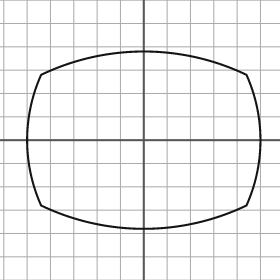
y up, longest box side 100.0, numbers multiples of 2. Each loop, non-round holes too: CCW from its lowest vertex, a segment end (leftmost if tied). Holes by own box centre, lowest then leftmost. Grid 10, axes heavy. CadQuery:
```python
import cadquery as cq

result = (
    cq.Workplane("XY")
    .moveTo(-44.0, -28.0)
    .threePointArc((0.0, -38.0), (44.0, -28.0))
    .threePointArc((50.0, 0.0), (44.0, 28.0))
    .threePointArc((0.0, 38.0), (-44.0, 28.0))
    .threePointArc((-50.0, 0.0), (-44.0, -28.0))
    .close()
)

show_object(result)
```